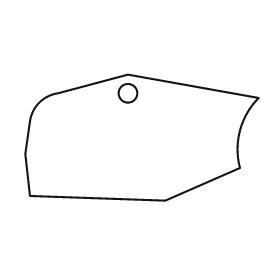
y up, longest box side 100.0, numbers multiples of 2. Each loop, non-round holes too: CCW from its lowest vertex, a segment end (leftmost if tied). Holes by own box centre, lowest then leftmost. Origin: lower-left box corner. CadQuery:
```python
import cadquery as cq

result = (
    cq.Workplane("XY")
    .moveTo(60.0, 0.0)
    .lineTo(92.0, 14.0)
    .threePointArc((92.0, 30.0), (100.0, 44.0))
    .lineTo(44.0, 54.0)
    .lineTo(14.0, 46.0)
    .threePointArc((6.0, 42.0), (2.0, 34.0))
    .lineTo(0.0, 20.0)
    .lineTo(2.0, 2.0)
    .close()
    .moveTo(44.0, 46.0)
    .circle(4.0)
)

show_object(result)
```